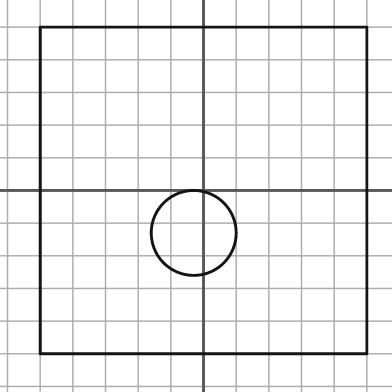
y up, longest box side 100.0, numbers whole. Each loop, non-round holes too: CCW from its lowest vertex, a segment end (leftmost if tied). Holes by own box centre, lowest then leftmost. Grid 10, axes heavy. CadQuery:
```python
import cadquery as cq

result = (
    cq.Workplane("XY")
    .moveTo(-50.0, -50.0)
    .lineTo(50.0, -50.0)
    .lineTo(50.0, 50.0)
    .lineTo(-50.0, 50.0)
    .close()
    .moveTo(-3.0, -13.0)
    .circle(13.0)
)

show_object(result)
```